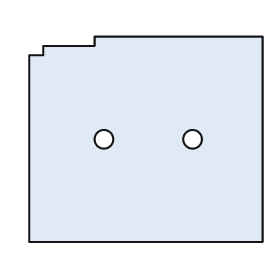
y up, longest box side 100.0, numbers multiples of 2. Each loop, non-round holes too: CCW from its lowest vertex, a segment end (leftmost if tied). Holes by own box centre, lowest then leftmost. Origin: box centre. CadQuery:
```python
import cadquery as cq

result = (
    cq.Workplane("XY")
    .moveTo(-50.0, -44.0)
    .lineTo(50.0, -44.0)
    .lineTo(50.0, 44.0)
    .lineTo(-22.0, 44.0)
    .lineTo(-22.0, 40.0)
    .lineTo(-44.0, 40.0)
    .lineTo(-44.0, 36.0)
    .lineTo(-50.0, 36.0)
    .close()
    .moveTo(-18.0, 0.0)
    .circle(4.0)
    .moveTo(20.0, 0.0)
    .circle(4.0)
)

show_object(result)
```